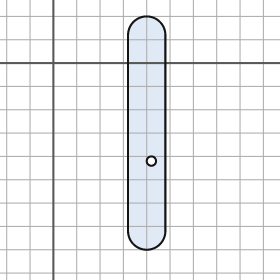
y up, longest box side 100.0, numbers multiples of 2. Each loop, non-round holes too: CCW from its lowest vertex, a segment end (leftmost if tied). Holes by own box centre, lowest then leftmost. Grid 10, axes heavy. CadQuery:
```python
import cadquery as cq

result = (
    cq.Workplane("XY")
    .moveTo(32.0, -72.0)
    .threePointArc((40.0, -80.0), (48.0, -72.0))
    .lineTo(48.0, 12.0)
    .threePointArc((40.0, 20.0), (32.0, 12.0))
    .close()
    .moveTo(42.0, -42.0)
    .circle(2.0)
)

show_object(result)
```